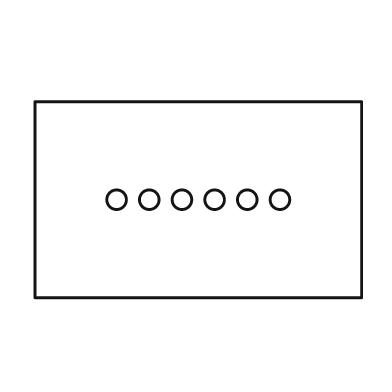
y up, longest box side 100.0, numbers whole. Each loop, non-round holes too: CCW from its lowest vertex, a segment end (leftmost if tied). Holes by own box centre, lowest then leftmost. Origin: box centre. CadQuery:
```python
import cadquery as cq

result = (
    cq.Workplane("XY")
    .moveTo(-50.0, -30.0)
    .lineTo(50.0, -30.0)
    .lineTo(50.0, 30.0)
    .lineTo(-50.0, 30.0)
    .close()
    .moveTo(-25.0, 0.0)
    .circle(3.0)
    .moveTo(-15.0, 0.0)
    .circle(3.0)
    .moveTo(-5.0, 0.0)
    .circle(3.0)
    .moveTo(5.0, 0.0)
    .circle(3.0)
    .moveTo(15.0, 0.0)
    .circle(3.0)
    .moveTo(25.0, 0.0)
    .circle(3.0)
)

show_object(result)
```